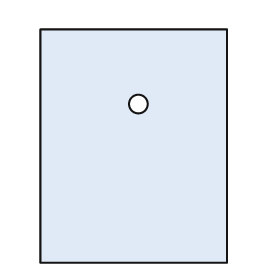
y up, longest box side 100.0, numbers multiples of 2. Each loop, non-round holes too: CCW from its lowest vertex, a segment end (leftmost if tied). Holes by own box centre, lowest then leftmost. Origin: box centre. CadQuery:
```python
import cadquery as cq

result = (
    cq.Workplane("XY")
    .moveTo(-40.0, -50.0)
    .lineTo(40.0, -50.0)
    .lineTo(40.0, 50.0)
    .lineTo(-40.0, 50.0)
    .close()
    .moveTo(2.0, 18.0)
    .circle(4.0)
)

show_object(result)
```